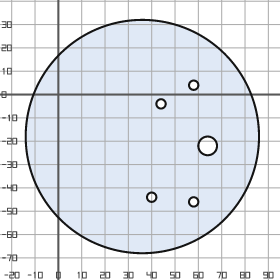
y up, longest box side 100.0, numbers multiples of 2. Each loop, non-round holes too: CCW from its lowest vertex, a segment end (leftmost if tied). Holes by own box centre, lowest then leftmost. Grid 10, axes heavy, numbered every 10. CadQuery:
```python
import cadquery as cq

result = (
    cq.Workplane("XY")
    .moveTo(36.0, -18.0)
    .circle(50.0)
    .moveTo(58.0, -46.0)
    .circle(2.0)
    .moveTo(40.0, -44.0)
    .circle(2.0)
    .moveTo(64.0, -22.0)
    .circle(4.0)
    .moveTo(44.0, -4.0)
    .circle(2.0)
    .moveTo(58.0, 4.0)
    .circle(2.0)
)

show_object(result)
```